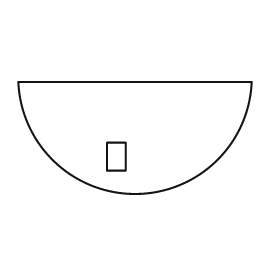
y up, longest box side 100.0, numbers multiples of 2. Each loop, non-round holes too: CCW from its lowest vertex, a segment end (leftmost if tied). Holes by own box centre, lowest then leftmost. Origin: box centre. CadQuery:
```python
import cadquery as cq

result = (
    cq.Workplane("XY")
    .moveTo(-50.0, 24.0)
    .threePointArc((0.0, -24.0), (50.0, 24.0))
    .close()
    .moveTo(-12.0, -14.0)
    .lineTo(-4.0, -14.0)
    .lineTo(-4.0, -2.0)
    .lineTo(-12.0, -2.0)
    .close()
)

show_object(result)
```